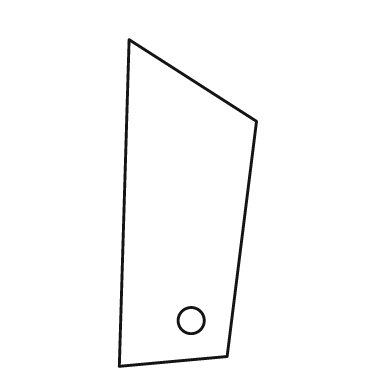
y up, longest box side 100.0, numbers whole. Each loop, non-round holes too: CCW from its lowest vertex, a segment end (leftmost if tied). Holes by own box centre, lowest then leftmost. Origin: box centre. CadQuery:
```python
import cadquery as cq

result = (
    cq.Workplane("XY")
    .moveTo(-21.0, -50.0)
    .lineTo(12.0, -47.0)
    .lineTo(21.0, 25.0)
    .lineTo(-18.0, 50.0)
    .close()
    .moveTo(1.0, -36.0)
    .circle(4.0)
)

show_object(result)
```